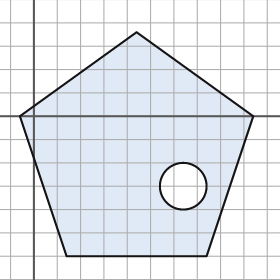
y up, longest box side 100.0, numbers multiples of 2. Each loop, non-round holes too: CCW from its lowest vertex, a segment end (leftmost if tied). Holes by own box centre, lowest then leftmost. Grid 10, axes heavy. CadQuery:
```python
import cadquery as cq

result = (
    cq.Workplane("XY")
    .moveTo(14.0, -60.0)
    .lineTo(74.0, -60.0)
    .lineTo(94.0, 0.0)
    .lineTo(44.0, 36.0)
    .lineTo(-6.0, 0.0)
    .close()
    .moveTo(64.0, -30.0)
    .circle(10.0)
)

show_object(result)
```